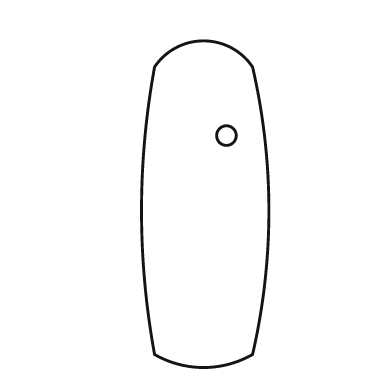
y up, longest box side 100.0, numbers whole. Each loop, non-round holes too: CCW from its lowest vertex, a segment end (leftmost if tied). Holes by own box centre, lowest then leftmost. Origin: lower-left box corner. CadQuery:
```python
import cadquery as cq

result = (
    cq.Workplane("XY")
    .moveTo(4.0, 4.0)
    .threePointArc((19.0, 0.0), (34.0, 4.0))
    .threePointArc((39.0, 48.0), (34.0, 92.0))
    .threePointArc((19.0, 100.0), (4.0, 92.0))
    .threePointArc((0.0, 48.0), (4.0, 4.0))
    .close()
    .moveTo(26.0, 71.0)
    .circle(3.0)
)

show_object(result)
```